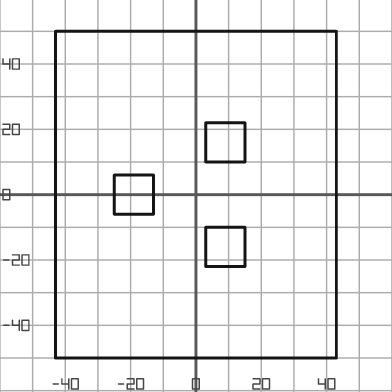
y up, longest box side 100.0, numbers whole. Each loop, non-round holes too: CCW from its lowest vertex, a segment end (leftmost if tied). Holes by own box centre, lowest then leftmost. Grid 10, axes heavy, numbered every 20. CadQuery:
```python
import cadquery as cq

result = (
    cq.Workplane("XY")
    .moveTo(-43.0, -50.0)
    .lineTo(43.0, -50.0)
    .lineTo(43.0, 50.0)
    .lineTo(-43.0, 50.0)
    .close()
    .moveTo(3.0, -22.0)
    .lineTo(15.0, -22.0)
    .lineTo(15.0, -10.0)
    .lineTo(3.0, -10.0)
    .close()
    .moveTo(-25.0, -6.0)
    .lineTo(-13.0, -6.0)
    .lineTo(-13.0, 6.0)
    .lineTo(-25.0, 6.0)
    .close()
    .moveTo(3.0, 10.0)
    .lineTo(15.0, 10.0)
    .lineTo(15.0, 22.0)
    .lineTo(3.0, 22.0)
    .close()
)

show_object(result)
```